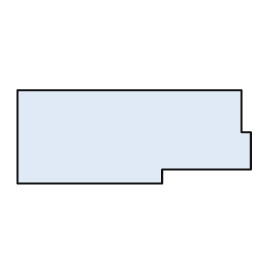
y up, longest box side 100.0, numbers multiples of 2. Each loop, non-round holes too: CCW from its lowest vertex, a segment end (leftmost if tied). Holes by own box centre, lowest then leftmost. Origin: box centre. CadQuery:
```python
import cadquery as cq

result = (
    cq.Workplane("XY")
    .moveTo(-50.0, -20.0)
    .lineTo(12.0, -20.0)
    .lineTo(12.0, -14.0)
    .lineTo(50.0, -14.0)
    .lineTo(50.0, 2.0)
    .lineTo(46.0, 2.0)
    .lineTo(46.0, 20.0)
    .lineTo(-50.0, 20.0)
    .close()
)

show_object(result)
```